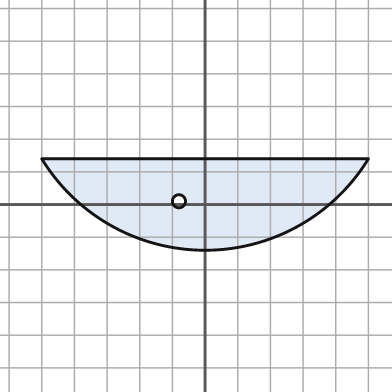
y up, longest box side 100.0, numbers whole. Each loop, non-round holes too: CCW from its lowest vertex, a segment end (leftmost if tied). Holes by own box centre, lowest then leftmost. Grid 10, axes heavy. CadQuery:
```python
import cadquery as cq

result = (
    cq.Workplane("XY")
    .moveTo(-50.0, 14.0)
    .threePointArc((0.0, -14.0), (50.0, 14.0))
    .close()
    .moveTo(-8.0, 1.0)
    .circle(2.0)
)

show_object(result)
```